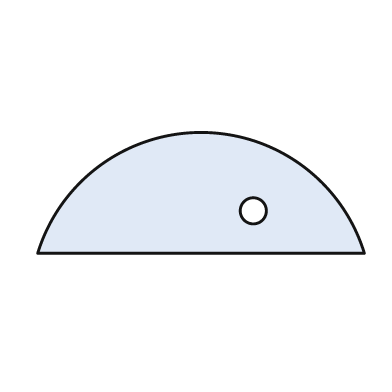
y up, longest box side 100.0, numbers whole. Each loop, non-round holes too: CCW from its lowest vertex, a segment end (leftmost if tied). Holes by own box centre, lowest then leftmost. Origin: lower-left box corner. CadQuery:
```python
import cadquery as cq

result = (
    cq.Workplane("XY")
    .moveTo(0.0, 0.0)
    .lineTo(100.0, 0.0)
    .threePointArc((50.0, 37.0), (0.0, 0.0))
    .close()
    .moveTo(66.0, 13.0)
    .circle(4.0)
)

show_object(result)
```